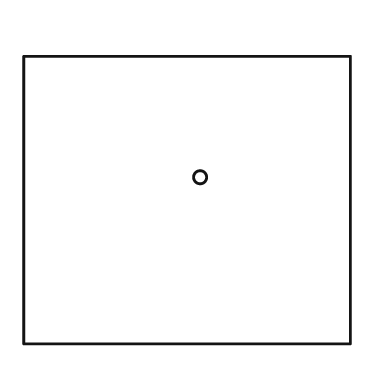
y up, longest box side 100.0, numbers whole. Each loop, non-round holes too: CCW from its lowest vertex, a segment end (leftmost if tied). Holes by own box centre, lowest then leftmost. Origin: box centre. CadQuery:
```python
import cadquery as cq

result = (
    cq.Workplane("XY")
    .moveTo(-50.0, -44.0)
    .lineTo(50.0, -44.0)
    .lineTo(50.0, 44.0)
    .lineTo(-50.0, 44.0)
    .close()
    .moveTo(4.0, 7.0)
    .circle(2.0)
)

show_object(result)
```